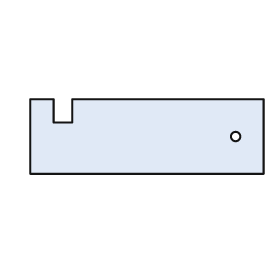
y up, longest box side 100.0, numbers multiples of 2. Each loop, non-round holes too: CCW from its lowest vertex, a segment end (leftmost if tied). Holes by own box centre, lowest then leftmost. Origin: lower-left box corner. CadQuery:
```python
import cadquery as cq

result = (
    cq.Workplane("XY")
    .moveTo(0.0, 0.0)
    .lineTo(100.0, 0.0)
    .lineTo(100.0, 32.0)
    .lineTo(18.0, 32.0)
    .lineTo(18.0, 22.0)
    .lineTo(10.0, 22.0)
    .lineTo(10.0, 32.0)
    .lineTo(0.0, 32.0)
    .close()
    .moveTo(88.0, 16.0)
    .circle(2.0)
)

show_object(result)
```